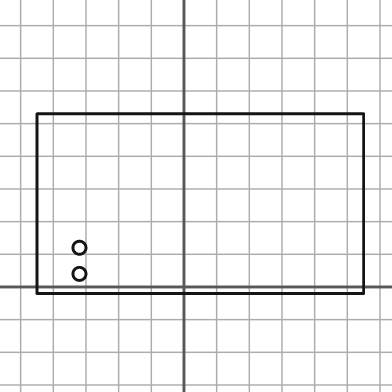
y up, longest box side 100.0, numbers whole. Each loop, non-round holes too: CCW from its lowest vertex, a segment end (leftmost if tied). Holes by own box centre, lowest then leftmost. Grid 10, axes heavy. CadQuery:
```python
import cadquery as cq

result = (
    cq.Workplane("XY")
    .moveTo(-45.0, -2.0)
    .lineTo(55.0, -2.0)
    .lineTo(55.0, 53.0)
    .lineTo(-45.0, 53.0)
    .close()
    .moveTo(-32.0, 4.0)
    .circle(2.0)
    .moveTo(-32.0, 12.0)
    .circle(2.0)
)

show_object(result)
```